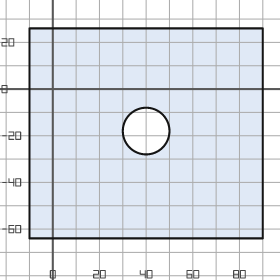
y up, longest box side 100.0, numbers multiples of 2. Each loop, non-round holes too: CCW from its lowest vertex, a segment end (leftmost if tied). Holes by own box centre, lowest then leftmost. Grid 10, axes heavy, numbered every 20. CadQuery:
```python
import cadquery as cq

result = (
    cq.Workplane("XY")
    .moveTo(-10.0, -64.0)
    .lineTo(90.0, -64.0)
    .lineTo(90.0, 26.0)
    .lineTo(-10.0, 26.0)
    .close()
    .moveTo(40.0, -18.0)
    .circle(10.0)
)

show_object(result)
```